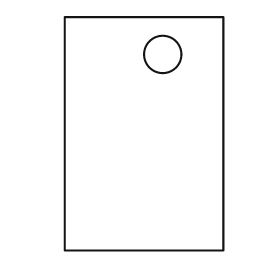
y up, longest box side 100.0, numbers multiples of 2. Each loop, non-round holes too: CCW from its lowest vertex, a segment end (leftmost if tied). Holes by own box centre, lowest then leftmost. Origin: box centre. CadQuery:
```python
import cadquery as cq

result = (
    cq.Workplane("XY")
    .moveTo(-34.0, -50.0)
    .lineTo(34.0, -50.0)
    .lineTo(34.0, 50.0)
    .lineTo(-34.0, 50.0)
    .close()
    .moveTo(8.0, 34.0)
    .circle(8.0)
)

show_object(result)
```